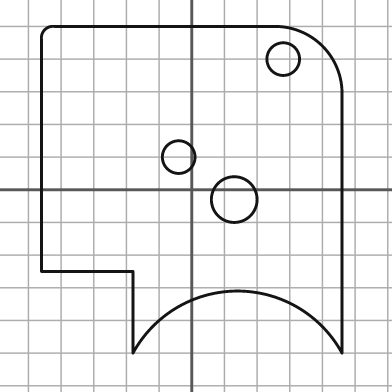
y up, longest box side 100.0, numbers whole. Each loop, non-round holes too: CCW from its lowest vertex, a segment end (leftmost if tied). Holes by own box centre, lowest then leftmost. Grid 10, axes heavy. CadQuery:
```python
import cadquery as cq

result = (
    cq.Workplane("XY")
    .moveTo(-18.0, -50.0)
    .threePointArc((14.0, -31.0), (46.0, -50.0))
    .lineTo(46.0, 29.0)
    .threePointArc((40.0, 44.0), (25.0, 50.0))
    .lineTo(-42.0, 50.0)
    .threePointArc((-45.0, 49.0), (-46.0, 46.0))
    .lineTo(-46.0, -25.0)
    .lineTo(-18.0, -25.0)
    .close()
    .moveTo(13.0, -3.0)
    .circle(7.0)
    .moveTo(-4.0, 10.0)
    .circle(5.0)
    .moveTo(28.0, 40.0)
    .circle(5.0)
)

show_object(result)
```